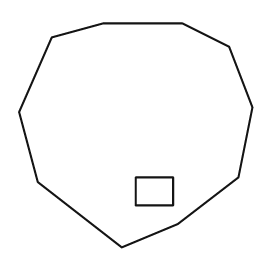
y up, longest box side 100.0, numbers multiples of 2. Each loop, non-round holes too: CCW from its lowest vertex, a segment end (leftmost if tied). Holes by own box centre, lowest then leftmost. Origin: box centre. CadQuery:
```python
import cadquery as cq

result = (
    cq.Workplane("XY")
    .moveTo(-6.0, -48.0)
    .lineTo(18.0, -38.0)
    .lineTo(44.0, -18.0)
    .lineTo(50.0, 12.0)
    .lineTo(40.0, 38.0)
    .lineTo(20.0, 48.0)
    .lineTo(-14.0, 48.0)
    .lineTo(-36.0, 42.0)
    .lineTo(-50.0, 10.0)
    .lineTo(-42.0, -20.0)
    .close()
    .moveTo(0.0, -30.0)
    .lineTo(16.0, -30.0)
    .lineTo(16.0, -18.0)
    .lineTo(0.0, -18.0)
    .close()
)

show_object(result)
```